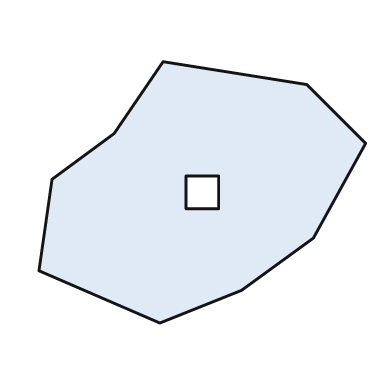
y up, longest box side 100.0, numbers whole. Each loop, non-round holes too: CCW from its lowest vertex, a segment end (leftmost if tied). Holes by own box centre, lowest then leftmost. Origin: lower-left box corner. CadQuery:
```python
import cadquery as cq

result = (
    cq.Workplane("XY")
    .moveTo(37.0, 0.0)
    .lineTo(62.0, 10.0)
    .lineTo(84.0, 26.0)
    .lineTo(100.0, 55.0)
    .lineTo(82.0, 73.0)
    .lineTo(38.0, 80.0)
    .lineTo(23.0, 58.0)
    .lineTo(4.0, 44.0)
    .lineTo(0.0, 16.0)
    .close()
    .moveTo(45.0, 35.0)
    .lineTo(55.0, 35.0)
    .lineTo(55.0, 45.0)
    .lineTo(45.0, 45.0)
    .close()
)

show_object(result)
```